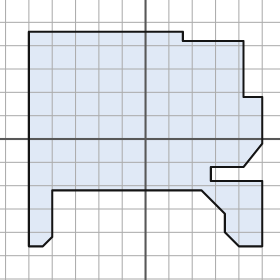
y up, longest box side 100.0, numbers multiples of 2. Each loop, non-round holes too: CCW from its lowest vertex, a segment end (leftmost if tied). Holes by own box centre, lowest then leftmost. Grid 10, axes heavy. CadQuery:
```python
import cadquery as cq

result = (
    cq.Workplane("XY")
    .moveTo(-50.0, -46.0)
    .lineTo(-44.0, -46.0)
    .lineTo(-40.0, -42.0)
    .lineTo(-40.0, -22.0)
    .lineTo(24.0, -22.0)
    .lineTo(34.0, -32.0)
    .lineTo(34.0, -40.0)
    .lineTo(40.0, -46.0)
    .lineTo(50.0, -46.0)
    .lineTo(50.0, -18.0)
    .lineTo(28.0, -18.0)
    .lineTo(28.0, -12.0)
    .lineTo(42.0, -12.0)
    .lineTo(50.0, -2.0)
    .lineTo(50.0, 18.0)
    .lineTo(42.0, 18.0)
    .lineTo(42.0, 42.0)
    .lineTo(16.0, 42.0)
    .lineTo(16.0, 46.0)
    .lineTo(-50.0, 46.0)
    .close()
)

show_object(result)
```